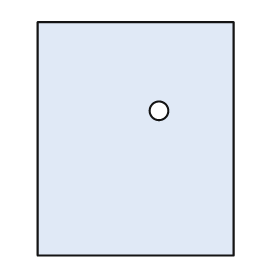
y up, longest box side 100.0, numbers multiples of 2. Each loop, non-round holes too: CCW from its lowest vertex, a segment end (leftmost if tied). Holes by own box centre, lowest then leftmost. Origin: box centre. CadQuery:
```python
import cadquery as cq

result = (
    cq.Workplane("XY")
    .moveTo(-42.0, -50.0)
    .lineTo(42.0, -50.0)
    .lineTo(42.0, 50.0)
    .lineTo(-42.0, 50.0)
    .close()
    .moveTo(10.0, 12.0)
    .circle(4.0)
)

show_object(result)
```